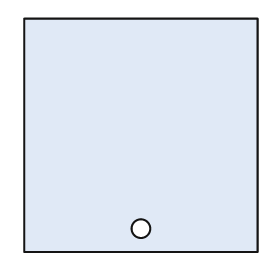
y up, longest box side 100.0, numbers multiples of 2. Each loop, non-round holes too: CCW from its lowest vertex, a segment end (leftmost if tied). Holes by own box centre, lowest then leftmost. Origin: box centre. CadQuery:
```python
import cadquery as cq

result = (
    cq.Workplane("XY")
    .moveTo(-50.0, -50.0)
    .lineTo(50.0, -50.0)
    .lineTo(50.0, 50.0)
    .lineTo(-50.0, 50.0)
    .close()
    .moveTo(0.0, -40.0)
    .circle(4.0)
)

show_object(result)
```